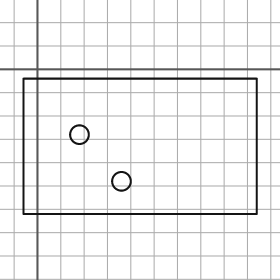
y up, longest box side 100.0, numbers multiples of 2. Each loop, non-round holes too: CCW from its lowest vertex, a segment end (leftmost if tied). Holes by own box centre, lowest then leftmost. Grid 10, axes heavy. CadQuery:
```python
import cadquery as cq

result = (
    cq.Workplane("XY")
    .moveTo(-6.0, -62.0)
    .lineTo(94.0, -62.0)
    .lineTo(94.0, -4.0)
    .lineTo(-6.0, -4.0)
    .close()
    .moveTo(36.0, -48.0)
    .circle(4.0)
    .moveTo(18.0, -28.0)
    .circle(4.0)
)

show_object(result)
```